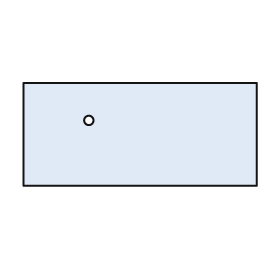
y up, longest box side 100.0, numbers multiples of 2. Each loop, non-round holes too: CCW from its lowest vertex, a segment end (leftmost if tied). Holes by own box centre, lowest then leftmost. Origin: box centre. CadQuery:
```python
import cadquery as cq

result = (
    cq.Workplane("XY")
    .moveTo(-50.0, -22.0)
    .lineTo(50.0, -22.0)
    .lineTo(50.0, 22.0)
    .lineTo(-50.0, 22.0)
    .close()
    .moveTo(-22.0, 6.0)
    .circle(2.0)
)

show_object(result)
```